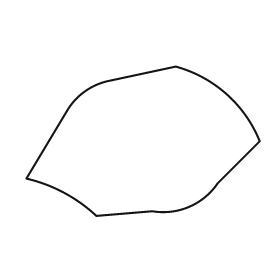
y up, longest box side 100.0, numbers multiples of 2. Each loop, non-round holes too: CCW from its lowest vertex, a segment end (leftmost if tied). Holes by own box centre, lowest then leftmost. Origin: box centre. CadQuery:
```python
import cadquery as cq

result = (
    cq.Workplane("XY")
    .moveTo(-20.0, -32.0)
    .lineTo(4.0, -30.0)
    .threePointArc((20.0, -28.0), (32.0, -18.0))
    .lineTo(50.0, 0.0)
    .threePointArc((36.0, 20.0), (14.0, 32.0))
    .lineTo(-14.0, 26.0)
    .threePointArc((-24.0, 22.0), (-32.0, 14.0))
    .lineTo(-50.0, -16.0)
    .threePointArc((-34.0, -22.0), (-20.0, -32.0))
    .close()
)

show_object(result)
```